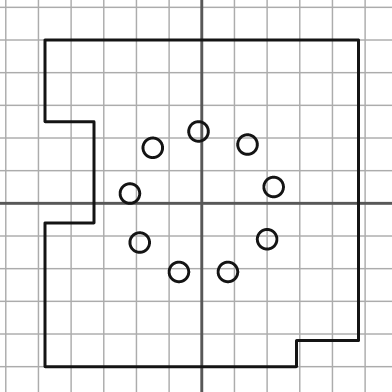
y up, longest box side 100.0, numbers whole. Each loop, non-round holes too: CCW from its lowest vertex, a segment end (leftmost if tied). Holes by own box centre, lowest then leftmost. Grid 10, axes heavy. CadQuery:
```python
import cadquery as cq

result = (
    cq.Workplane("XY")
    .moveTo(-48.0, -50.0)
    .lineTo(29.0, -50.0)
    .lineTo(29.0, -42.0)
    .lineTo(48.0, -42.0)
    .lineTo(48.0, 50.0)
    .lineTo(-48.0, 50.0)
    .lineTo(-48.0, 25.0)
    .lineTo(-33.0, 25.0)
    .lineTo(-33.0, -6.0)
    .lineTo(-48.0, -6.0)
    .close()
    .moveTo(-7.0, -21.0)
    .circle(3.0)
    .moveTo(8.0, -21.0)
    .circle(3.0)
    .moveTo(-19.0, -12.0)
    .circle(3.0)
    .moveTo(20.0, -11.0)
    .circle(3.0)
    .moveTo(-22.0, 3.0)
    .circle(3.0)
    .moveTo(22.0, 5.0)
    .circle(3.0)
    .moveTo(-15.0, 17.0)
    .circle(3.0)
    .moveTo(14.0, 18.0)
    .circle(3.0)
    .moveTo(-1.0, 22.0)
    .circle(3.0)
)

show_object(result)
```